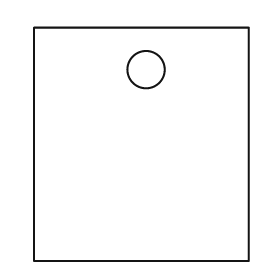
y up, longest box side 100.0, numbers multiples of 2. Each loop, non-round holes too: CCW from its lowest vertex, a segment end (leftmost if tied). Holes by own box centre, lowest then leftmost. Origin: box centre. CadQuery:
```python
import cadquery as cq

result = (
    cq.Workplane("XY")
    .moveTo(-46.0, -50.0)
    .lineTo(46.0, -50.0)
    .lineTo(46.0, 50.0)
    .lineTo(-46.0, 50.0)
    .close()
    .moveTo(2.0, 32.0)
    .circle(8.0)
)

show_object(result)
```